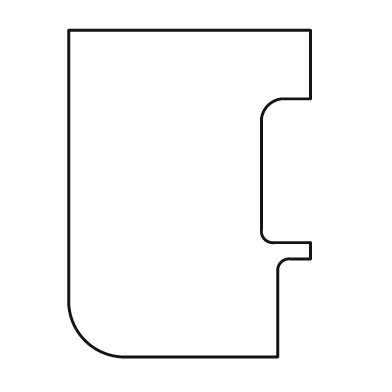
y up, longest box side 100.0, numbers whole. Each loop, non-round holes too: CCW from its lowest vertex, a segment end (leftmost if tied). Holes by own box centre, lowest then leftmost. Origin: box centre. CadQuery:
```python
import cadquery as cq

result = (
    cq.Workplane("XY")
    .moveTo(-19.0, -50.0)
    .lineTo(27.0, -50.0)
    .lineTo(27.0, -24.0)
    .threePointArc((28.0, -21.0), (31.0, -20.0))
    .lineTo(37.0, -20.0)
    .lineTo(37.0, -15.0)
    .lineTo(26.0, -15.0)
    .threePointArc((23.0, -14.0), (22.0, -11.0))
    .lineTo(22.0, 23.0)
    .threePointArc((24.0, 27.0), (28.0, 29.0))
    .lineTo(37.0, 29.0)
    .lineTo(37.0, 50.0)
    .lineTo(-37.0, 50.0)
    .lineTo(-37.0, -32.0)
    .threePointArc((-32.0, -45.0), (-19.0, -50.0))
    .close()
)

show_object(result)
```